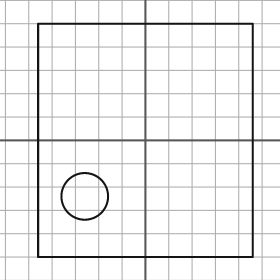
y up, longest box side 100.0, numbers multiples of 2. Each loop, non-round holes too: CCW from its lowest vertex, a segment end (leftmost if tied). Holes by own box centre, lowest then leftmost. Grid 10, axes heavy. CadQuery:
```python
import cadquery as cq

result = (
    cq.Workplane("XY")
    .moveTo(-46.0, -50.0)
    .lineTo(46.0, -50.0)
    .lineTo(46.0, 50.0)
    .lineTo(-46.0, 50.0)
    .close()
    .moveTo(-26.0, -24.0)
    .circle(10.0)
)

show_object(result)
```